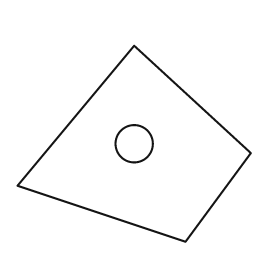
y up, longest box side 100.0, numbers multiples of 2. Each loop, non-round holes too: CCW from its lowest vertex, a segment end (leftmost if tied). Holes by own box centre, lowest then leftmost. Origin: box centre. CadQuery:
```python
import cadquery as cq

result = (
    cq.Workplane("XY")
    .moveTo(22.0, -42.0)
    .lineTo(50.0, -4.0)
    .lineTo(0.0, 42.0)
    .lineTo(-50.0, -18.0)
    .close()
    .moveTo(0.0, 0.0)
    .circle(8.0)
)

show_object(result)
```